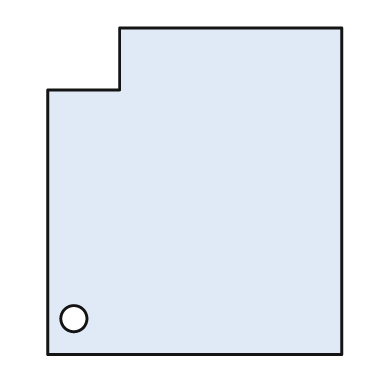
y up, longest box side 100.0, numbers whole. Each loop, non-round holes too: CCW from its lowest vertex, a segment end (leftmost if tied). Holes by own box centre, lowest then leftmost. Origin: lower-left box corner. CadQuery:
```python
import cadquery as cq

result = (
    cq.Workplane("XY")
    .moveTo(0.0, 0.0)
    .lineTo(90.0, 0.0)
    .lineTo(90.0, 100.0)
    .lineTo(22.0, 100.0)
    .lineTo(22.0, 81.0)
    .lineTo(0.0, 81.0)
    .close()
    .moveTo(8.0, 11.0)
    .circle(4.0)
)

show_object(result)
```